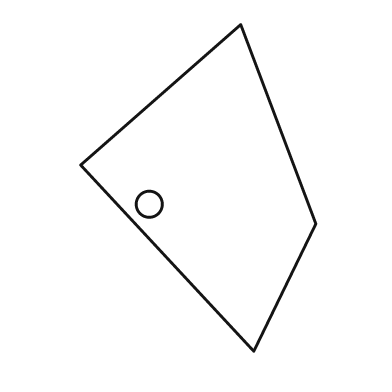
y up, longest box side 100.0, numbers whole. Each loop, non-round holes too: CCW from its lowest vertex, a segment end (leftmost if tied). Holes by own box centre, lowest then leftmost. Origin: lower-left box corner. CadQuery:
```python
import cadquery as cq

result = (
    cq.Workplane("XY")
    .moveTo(53.0, 0.0)
    .lineTo(72.0, 39.0)
    .lineTo(49.0, 100.0)
    .lineTo(0.0, 57.0)
    .close()
    .moveTo(21.0, 45.0)
    .circle(4.0)
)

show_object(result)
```